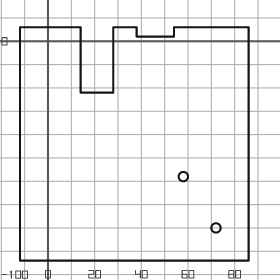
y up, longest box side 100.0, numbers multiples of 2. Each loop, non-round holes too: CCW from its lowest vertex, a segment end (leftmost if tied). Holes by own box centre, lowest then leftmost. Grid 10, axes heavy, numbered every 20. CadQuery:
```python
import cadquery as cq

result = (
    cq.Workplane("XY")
    .moveTo(-12.0, -94.0)
    .lineTo(86.0, -94.0)
    .lineTo(86.0, 6.0)
    .lineTo(54.0, 6.0)
    .lineTo(54.0, 2.0)
    .lineTo(38.0, 2.0)
    .lineTo(38.0, 6.0)
    .lineTo(28.0, 6.0)
    .lineTo(28.0, -22.0)
    .lineTo(14.0, -22.0)
    .lineTo(14.0, 6.0)
    .lineTo(-12.0, 6.0)
    .close()
    .moveTo(72.0, -80.0)
    .circle(2.0)
    .moveTo(58.0, -58.0)
    .circle(2.0)
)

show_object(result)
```